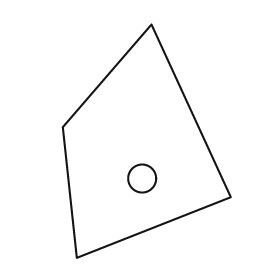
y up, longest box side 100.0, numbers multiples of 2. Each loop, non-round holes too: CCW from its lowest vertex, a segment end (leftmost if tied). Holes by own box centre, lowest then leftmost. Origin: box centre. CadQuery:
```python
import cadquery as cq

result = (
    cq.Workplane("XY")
    .moveTo(-30.0, -50.0)
    .lineTo(36.0, -24.0)
    .lineTo(2.0, 50.0)
    .lineTo(-36.0, 6.0)
    .close()
    .moveTo(-2.0, -16.0)
    .circle(6.0)
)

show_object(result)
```